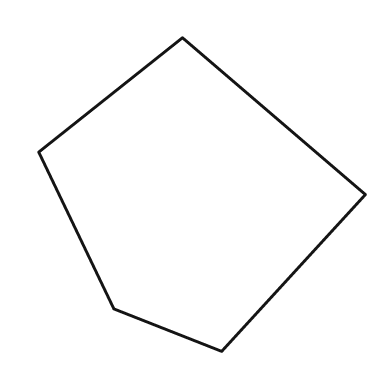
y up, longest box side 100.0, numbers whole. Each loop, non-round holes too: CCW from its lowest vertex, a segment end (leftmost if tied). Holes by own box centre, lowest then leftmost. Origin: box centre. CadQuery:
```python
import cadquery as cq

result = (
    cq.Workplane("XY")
    .moveTo(6.0, -48.0)
    .lineTo(50.0, 0.0)
    .lineTo(-6.0, 48.0)
    .lineTo(-50.0, 13.0)
    .lineTo(-27.0, -35.0)
    .close()
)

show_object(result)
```